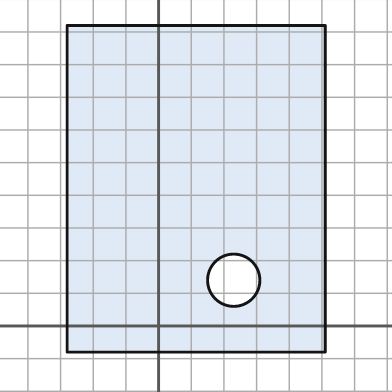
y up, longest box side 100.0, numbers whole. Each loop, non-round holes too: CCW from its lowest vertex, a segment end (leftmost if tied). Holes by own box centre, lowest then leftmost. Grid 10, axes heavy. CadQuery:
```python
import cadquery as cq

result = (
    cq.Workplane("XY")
    .moveTo(-28.0, -8.0)
    .lineTo(51.0, -8.0)
    .lineTo(51.0, 92.0)
    .lineTo(-28.0, 92.0)
    .close()
    .moveTo(23.0, 14.0)
    .circle(8.0)
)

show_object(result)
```